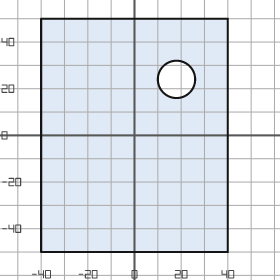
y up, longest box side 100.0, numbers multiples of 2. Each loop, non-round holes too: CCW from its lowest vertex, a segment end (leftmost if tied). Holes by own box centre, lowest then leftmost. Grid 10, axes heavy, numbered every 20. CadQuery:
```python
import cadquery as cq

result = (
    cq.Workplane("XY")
    .moveTo(-40.0, -50.0)
    .lineTo(40.0, -50.0)
    .lineTo(40.0, 50.0)
    .lineTo(-40.0, 50.0)
    .close()
    .moveTo(18.0, 24.0)
    .circle(8.0)
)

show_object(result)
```